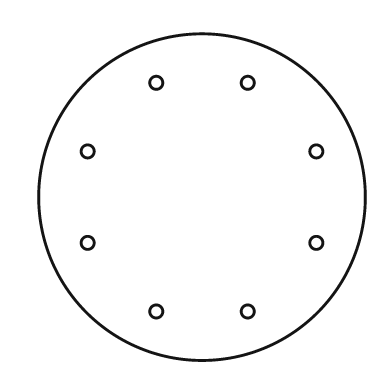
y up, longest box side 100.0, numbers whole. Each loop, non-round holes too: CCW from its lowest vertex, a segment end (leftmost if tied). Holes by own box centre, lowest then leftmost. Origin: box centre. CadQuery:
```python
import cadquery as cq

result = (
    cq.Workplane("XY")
    .moveTo(0.0, 0.0)
    .circle(50.0)
    .moveTo(-14.0, -35.0)
    .circle(2.0)
    .moveTo(14.0, -35.0)
    .circle(2.0)
    .moveTo(-35.0, -14.0)
    .circle(2.0)
    .moveTo(35.0, -14.0)
    .circle(2.0)
    .moveTo(-35.0, 14.0)
    .circle(2.0)
    .moveTo(35.0, 14.0)
    .circle(2.0)
    .moveTo(-14.0, 35.0)
    .circle(2.0)
    .moveTo(14.0, 35.0)
    .circle(2.0)
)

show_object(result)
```